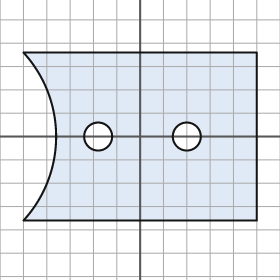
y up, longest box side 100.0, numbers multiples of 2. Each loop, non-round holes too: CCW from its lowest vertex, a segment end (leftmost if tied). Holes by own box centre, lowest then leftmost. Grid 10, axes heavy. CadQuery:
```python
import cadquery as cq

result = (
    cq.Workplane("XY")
    .moveTo(-50.0, -36.0)
    .lineTo(50.0, -36.0)
    .lineTo(50.0, 36.0)
    .lineTo(-50.0, 36.0)
    .threePointArc((-36.0, 0.0), (-50.0, -36.0))
    .close()
    .moveTo(-18.0, 0.0)
    .circle(6.0)
    .moveTo(20.0, 0.0)
    .circle(6.0)
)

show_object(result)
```